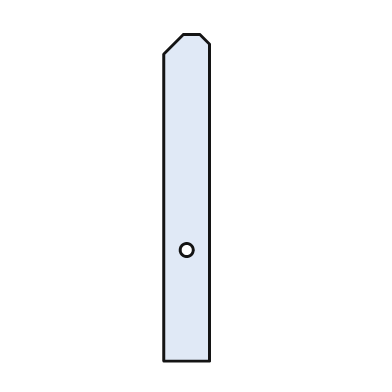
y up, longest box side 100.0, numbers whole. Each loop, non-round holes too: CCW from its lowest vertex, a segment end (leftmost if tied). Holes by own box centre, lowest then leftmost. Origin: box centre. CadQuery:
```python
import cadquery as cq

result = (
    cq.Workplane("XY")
    .moveTo(-7.0, -50.0)
    .lineTo(7.0, -50.0)
    .lineTo(7.0, 47.0)
    .lineTo(4.0, 50.0)
    .lineTo(-1.0, 50.0)
    .lineTo(-7.0, 44.0)
    .close()
    .moveTo(0.0, -16.0)
    .circle(2.0)
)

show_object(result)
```